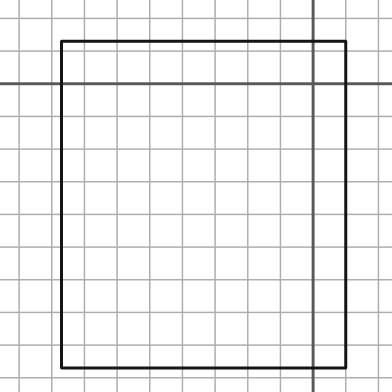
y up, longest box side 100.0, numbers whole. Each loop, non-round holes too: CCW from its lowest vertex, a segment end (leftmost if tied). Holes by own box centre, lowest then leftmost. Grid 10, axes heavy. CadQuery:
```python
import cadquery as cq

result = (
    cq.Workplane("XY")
    .moveTo(-77.0, -87.0)
    .lineTo(10.0, -87.0)
    .lineTo(10.0, 13.0)
    .lineTo(-77.0, 13.0)
    .close()
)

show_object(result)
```